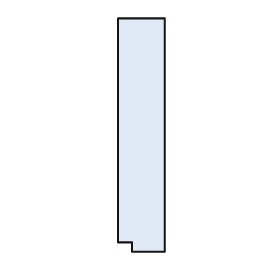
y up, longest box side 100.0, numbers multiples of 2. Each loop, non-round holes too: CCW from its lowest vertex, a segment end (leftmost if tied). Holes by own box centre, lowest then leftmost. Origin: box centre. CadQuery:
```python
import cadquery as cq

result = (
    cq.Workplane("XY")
    .moveTo(-4.0, -50.0)
    .lineTo(10.0, -50.0)
    .lineTo(10.0, 50.0)
    .lineTo(-10.0, 50.0)
    .lineTo(-10.0, -46.0)
    .lineTo(-4.0, -46.0)
    .close()
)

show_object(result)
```